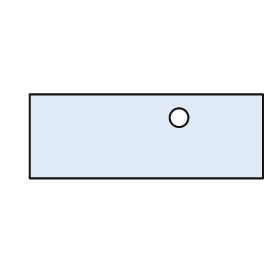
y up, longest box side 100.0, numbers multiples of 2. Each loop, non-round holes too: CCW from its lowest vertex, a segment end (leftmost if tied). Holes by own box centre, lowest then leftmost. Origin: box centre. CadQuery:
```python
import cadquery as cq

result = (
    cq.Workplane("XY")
    .moveTo(-50.0, -18.0)
    .lineTo(50.0, -18.0)
    .lineTo(50.0, 18.0)
    .lineTo(-50.0, 18.0)
    .close()
    .moveTo(14.0, 8.0)
    .circle(4.0)
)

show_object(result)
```